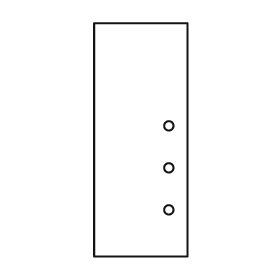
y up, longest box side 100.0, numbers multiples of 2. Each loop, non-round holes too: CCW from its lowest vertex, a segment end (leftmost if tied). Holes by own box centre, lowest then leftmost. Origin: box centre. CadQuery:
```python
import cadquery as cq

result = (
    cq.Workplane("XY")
    .moveTo(-20.0, -50.0)
    .lineTo(20.0, -50.0)
    .lineTo(20.0, 50.0)
    .lineTo(-20.0, 50.0)
    .close()
    .moveTo(12.0, -30.0)
    .circle(2.0)
    .moveTo(12.0, -12.0)
    .circle(2.0)
    .moveTo(12.0, 6.0)
    .circle(2.0)
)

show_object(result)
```